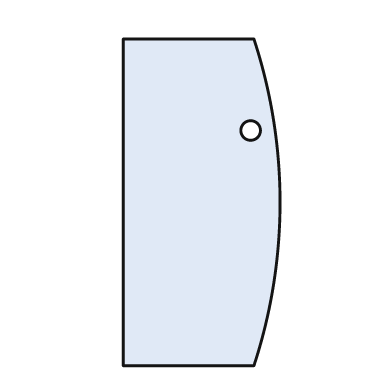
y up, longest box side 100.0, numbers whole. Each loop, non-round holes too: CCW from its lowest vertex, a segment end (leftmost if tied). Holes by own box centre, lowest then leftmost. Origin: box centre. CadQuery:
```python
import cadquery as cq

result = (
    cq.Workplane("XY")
    .moveTo(-24.0, -50.0)
    .lineTo(16.0, -50.0)
    .threePointArc((24.0, 0.0), (16.0, 50.0))
    .lineTo(-24.0, 50.0)
    .close()
    .moveTo(15.0, 22.0)
    .circle(3.0)
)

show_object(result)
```